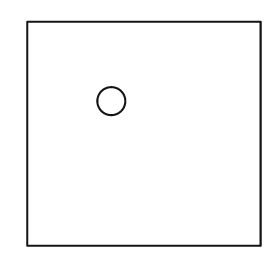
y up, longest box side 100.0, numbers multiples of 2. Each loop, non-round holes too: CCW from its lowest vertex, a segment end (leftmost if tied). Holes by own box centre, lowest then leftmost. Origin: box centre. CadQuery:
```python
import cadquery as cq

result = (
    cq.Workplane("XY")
    .moveTo(-50.0, -48.0)
    .lineTo(50.0, -48.0)
    .lineTo(50.0, 48.0)
    .lineTo(-50.0, 48.0)
    .close()
    .moveTo(-14.0, 14.0)
    .circle(6.0)
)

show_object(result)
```